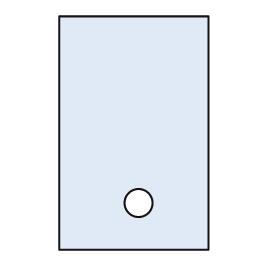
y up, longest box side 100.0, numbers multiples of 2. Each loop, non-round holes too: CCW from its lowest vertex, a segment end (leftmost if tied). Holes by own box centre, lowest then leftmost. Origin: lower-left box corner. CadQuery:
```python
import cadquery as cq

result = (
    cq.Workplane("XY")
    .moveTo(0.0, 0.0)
    .lineTo(64.0, 0.0)
    .lineTo(64.0, 100.0)
    .lineTo(0.0, 100.0)
    .close()
    .moveTo(34.0, 20.0)
    .circle(6.0)
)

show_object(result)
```